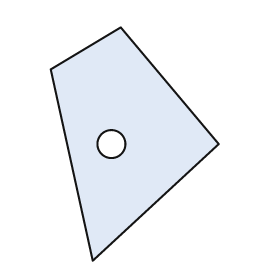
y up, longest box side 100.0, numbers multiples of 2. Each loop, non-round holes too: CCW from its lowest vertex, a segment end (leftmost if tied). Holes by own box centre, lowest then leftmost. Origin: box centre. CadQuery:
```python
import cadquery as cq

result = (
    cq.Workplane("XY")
    .moveTo(-18.0, -50.0)
    .lineTo(36.0, 0.0)
    .lineTo(-6.0, 50.0)
    .lineTo(-36.0, 32.0)
    .close()
    .moveTo(-10.0, 0.0)
    .circle(6.0)
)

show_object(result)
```